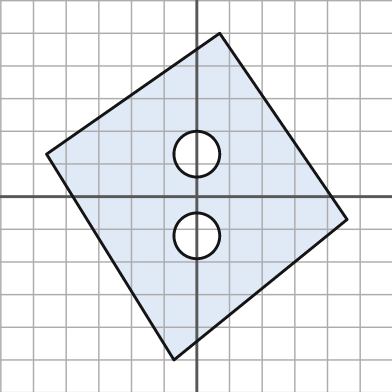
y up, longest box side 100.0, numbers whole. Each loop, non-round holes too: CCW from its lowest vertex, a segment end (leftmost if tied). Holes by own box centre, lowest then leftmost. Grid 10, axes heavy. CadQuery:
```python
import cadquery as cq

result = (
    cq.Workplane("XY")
    .moveTo(-7.0, -50.0)
    .lineTo(46.0, -7.0)
    .lineTo(7.0, 50.0)
    .lineTo(-46.0, 13.0)
    .close()
    .moveTo(0.0, -12.0)
    .circle(7.0)
    .moveTo(0.0, 13.0)
    .circle(7.0)
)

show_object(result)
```